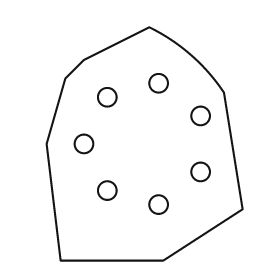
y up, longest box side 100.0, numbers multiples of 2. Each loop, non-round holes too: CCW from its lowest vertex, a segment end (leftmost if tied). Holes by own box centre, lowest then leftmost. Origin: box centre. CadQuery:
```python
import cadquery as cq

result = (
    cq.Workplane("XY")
    .moveTo(-36.0, -50.0)
    .lineTo(8.0, -50.0)
    .lineTo(42.0, -28.0)
    .lineTo(34.0, 22.0)
    .threePointArc((20.0, 38.0), (2.0, 50.0))
    .lineTo(-26.0, 36.0)
    .lineTo(-34.0, 28.0)
    .lineTo(-42.0, 0.0)
    .close()
    .moveTo(6.0, -26.0)
    .circle(4.0)
    .moveTo(-16.0, -20.0)
    .circle(4.0)
    .moveTo(24.0, -12.0)
    .circle(4.0)
    .moveTo(-26.0, 0.0)
    .circle(4.0)
    .moveTo(24.0, 12.0)
    .circle(4.0)
    .moveTo(-16.0, 20.0)
    .circle(4.0)
    .moveTo(6.0, 26.0)
    .circle(4.0)
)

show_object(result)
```